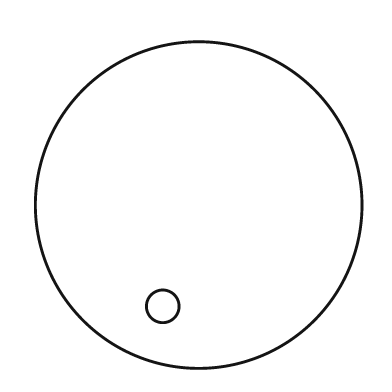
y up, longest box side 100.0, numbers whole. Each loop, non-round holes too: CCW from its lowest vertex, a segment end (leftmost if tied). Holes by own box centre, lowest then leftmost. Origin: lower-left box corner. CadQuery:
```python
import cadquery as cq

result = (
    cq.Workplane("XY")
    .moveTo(50.0, 50.0)
    .circle(50.0)
    .moveTo(39.0, 19.0)
    .circle(5.0)
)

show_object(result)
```